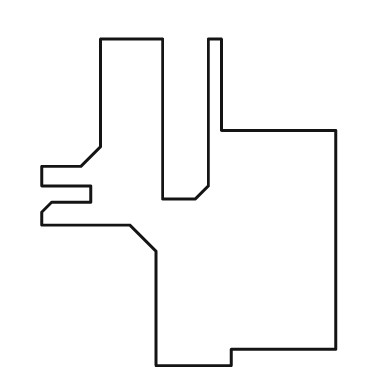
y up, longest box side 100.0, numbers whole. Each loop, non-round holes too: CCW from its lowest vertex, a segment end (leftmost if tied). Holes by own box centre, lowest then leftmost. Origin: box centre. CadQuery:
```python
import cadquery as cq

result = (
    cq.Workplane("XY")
    .moveTo(-10.0, -50.0)
    .lineTo(13.0, -50.0)
    .lineTo(13.0, -45.0)
    .lineTo(45.0, -45.0)
    .lineTo(45.0, 22.0)
    .lineTo(10.0, 22.0)
    .lineTo(10.0, 50.0)
    .lineTo(6.0, 50.0)
    .lineTo(6.0, 5.0)
    .lineTo(2.0, 1.0)
    .lineTo(-8.0, 1.0)
    .lineTo(-8.0, 50.0)
    .lineTo(-27.0, 50.0)
    .lineTo(-27.0, 17.0)
    .lineTo(-33.0, 11.0)
    .lineTo(-45.0, 11.0)
    .lineTo(-45.0, 5.0)
    .lineTo(-30.0, 5.0)
    .lineTo(-30.0, 0.0)
    .lineTo(-42.0, 0.0)
    .lineTo(-45.0, -3.0)
    .lineTo(-45.0, -7.0)
    .lineTo(-18.0, -7.0)
    .lineTo(-10.0, -15.0)
    .close()
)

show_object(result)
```